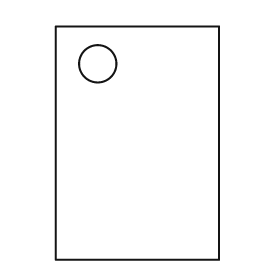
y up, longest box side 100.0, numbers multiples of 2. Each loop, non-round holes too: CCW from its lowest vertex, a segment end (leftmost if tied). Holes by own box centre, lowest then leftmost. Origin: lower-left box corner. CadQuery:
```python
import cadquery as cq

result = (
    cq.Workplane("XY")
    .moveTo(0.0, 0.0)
    .lineTo(70.0, 0.0)
    .lineTo(70.0, 100.0)
    .lineTo(0.0, 100.0)
    .close()
    .moveTo(18.0, 84.0)
    .circle(8.0)
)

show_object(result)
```